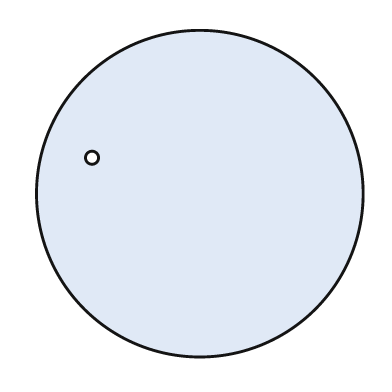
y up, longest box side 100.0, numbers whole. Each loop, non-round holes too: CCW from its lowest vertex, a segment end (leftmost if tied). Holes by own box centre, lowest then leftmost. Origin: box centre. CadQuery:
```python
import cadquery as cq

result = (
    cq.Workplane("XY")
    .moveTo(0.0, 0.0)
    .circle(50.0)
    .moveTo(-33.0, 11.0)
    .circle(2.0)
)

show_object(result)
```